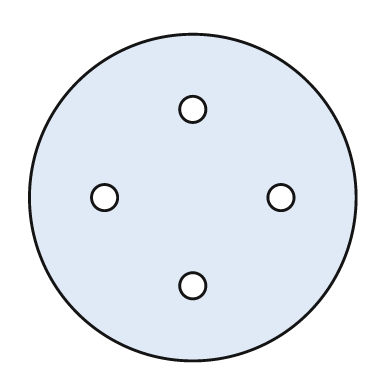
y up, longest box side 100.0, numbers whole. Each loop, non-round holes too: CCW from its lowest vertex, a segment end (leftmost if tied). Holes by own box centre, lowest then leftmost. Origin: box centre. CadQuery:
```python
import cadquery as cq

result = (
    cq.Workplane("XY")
    .moveTo(0.0, 0.0)
    .circle(50.0)
    .moveTo(0.0, -27.0)
    .circle(4.0)
    .moveTo(-27.0, 0.0)
    .circle(4.0)
    .moveTo(27.0, 0.0)
    .circle(4.0)
    .moveTo(0.0, 27.0)
    .circle(4.0)
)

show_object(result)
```